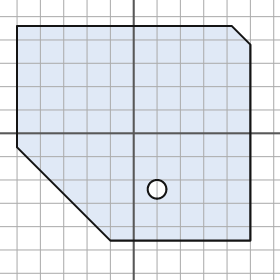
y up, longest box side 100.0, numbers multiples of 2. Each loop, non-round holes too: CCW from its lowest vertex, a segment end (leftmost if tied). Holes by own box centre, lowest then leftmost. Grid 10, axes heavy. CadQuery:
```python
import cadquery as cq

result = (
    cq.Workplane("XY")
    .moveTo(-10.0, -46.0)
    .lineTo(50.0, -46.0)
    .lineTo(50.0, 38.0)
    .lineTo(42.0, 46.0)
    .lineTo(-50.0, 46.0)
    .lineTo(-50.0, -6.0)
    .close()
    .moveTo(10.0, -24.0)
    .circle(4.0)
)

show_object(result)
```